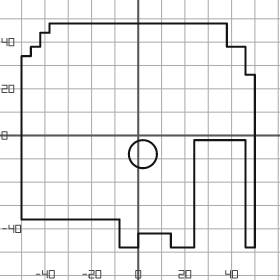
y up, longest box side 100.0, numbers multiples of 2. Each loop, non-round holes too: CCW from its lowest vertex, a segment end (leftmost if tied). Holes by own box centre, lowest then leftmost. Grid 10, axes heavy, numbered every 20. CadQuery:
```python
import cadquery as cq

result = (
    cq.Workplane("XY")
    .moveTo(-8.0, -48.0)
    .lineTo(0.0, -48.0)
    .lineTo(0.0, -42.0)
    .lineTo(14.0, -42.0)
    .lineTo(14.0, -48.0)
    .lineTo(24.0, -48.0)
    .lineTo(24.0, -2.0)
    .lineTo(46.0, -2.0)
    .lineTo(46.0, -48.0)
    .lineTo(50.0, -48.0)
    .lineTo(50.0, 26.0)
    .lineTo(46.0, 26.0)
    .lineTo(46.0, 38.0)
    .lineTo(38.0, 38.0)
    .lineTo(38.0, 48.0)
    .lineTo(-38.0, 48.0)
    .lineTo(-38.0, 44.0)
    .lineTo(-42.0, 44.0)
    .lineTo(-42.0, 38.0)
    .lineTo(-46.0, 38.0)
    .lineTo(-46.0, 34.0)
    .lineTo(-50.0, 34.0)
    .lineTo(-50.0, -36.0)
    .lineTo(-8.0, -36.0)
    .close()
    .moveTo(2.0, -8.0)
    .circle(6.0)
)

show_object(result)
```